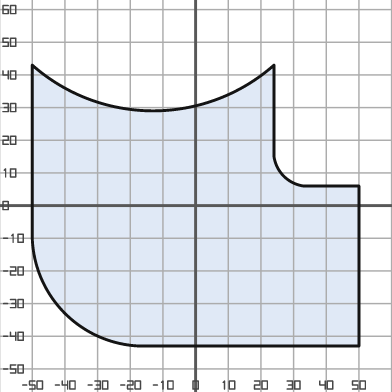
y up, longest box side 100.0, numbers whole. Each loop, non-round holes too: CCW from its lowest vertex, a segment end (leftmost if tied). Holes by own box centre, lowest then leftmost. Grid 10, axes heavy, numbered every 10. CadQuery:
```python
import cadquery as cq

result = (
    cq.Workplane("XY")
    .moveTo(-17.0, -43.0)
    .lineTo(50.0, -43.0)
    .lineTo(50.0, 6.0)
    .lineTo(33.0, 6.0)
    .threePointArc((27.0, 9.0), (24.0, 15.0))
    .lineTo(24.0, 43.0)
    .threePointArc((-13.0, 29.0), (-50.0, 43.0))
    .lineTo(-50.0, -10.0)
    .threePointArc((-40.0, -33.0), (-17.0, -43.0))
    .close()
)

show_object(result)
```